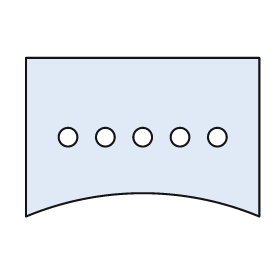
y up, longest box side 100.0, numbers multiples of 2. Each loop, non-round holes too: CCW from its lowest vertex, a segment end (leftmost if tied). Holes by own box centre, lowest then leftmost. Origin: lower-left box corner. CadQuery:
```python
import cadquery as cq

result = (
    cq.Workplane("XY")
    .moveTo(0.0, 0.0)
    .threePointArc((50.0, 10.0), (100.0, 0.0))
    .lineTo(100.0, 68.0)
    .lineTo(0.0, 68.0)
    .close()
    .moveTo(18.0, 34.0)
    .circle(4.0)
    .moveTo(34.0, 34.0)
    .circle(4.0)
    .moveTo(50.0, 34.0)
    .circle(4.0)
    .moveTo(66.0, 34.0)
    .circle(4.0)
    .moveTo(82.0, 34.0)
    .circle(4.0)
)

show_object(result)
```